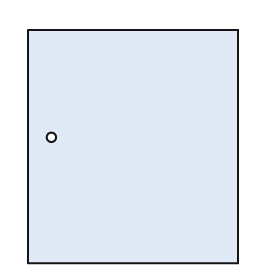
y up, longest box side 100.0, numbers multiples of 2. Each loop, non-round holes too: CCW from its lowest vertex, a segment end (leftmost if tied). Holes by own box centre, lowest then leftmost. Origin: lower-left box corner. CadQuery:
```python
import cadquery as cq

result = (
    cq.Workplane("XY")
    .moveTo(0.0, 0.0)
    .lineTo(90.0, 0.0)
    .lineTo(90.0, 100.0)
    .lineTo(0.0, 100.0)
    .close()
    .moveTo(10.0, 54.0)
    .circle(2.0)
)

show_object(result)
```